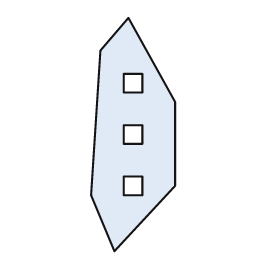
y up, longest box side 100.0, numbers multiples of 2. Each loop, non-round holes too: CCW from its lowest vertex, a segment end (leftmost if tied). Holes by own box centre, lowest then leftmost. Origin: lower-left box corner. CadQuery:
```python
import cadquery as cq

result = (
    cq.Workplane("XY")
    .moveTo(10.0, 0.0)
    .lineTo(36.0, 28.0)
    .lineTo(36.0, 64.0)
    .lineTo(16.0, 100.0)
    .lineTo(4.0, 86.0)
    .lineTo(0.0, 24.0)
    .close()
    .moveTo(14.0, 24.0)
    .lineTo(22.0, 24.0)
    .lineTo(22.0, 32.0)
    .lineTo(14.0, 32.0)
    .close()
    .moveTo(14.0, 46.0)
    .lineTo(22.0, 46.0)
    .lineTo(22.0, 54.0)
    .lineTo(14.0, 54.0)
    .close()
    .moveTo(14.0, 68.0)
    .lineTo(22.0, 68.0)
    .lineTo(22.0, 76.0)
    .lineTo(14.0, 76.0)
    .close()
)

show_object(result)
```